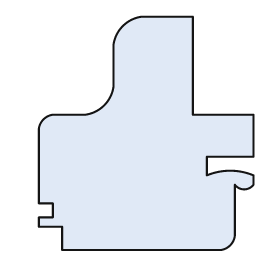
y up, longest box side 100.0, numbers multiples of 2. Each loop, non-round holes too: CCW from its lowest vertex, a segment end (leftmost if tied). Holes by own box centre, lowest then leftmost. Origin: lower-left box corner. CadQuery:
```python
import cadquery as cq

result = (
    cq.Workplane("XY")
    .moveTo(10.0, 0.0)
    .lineTo(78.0, 0.0)
    .threePointArc((82.0, 2.0), (84.0, 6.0))
    .lineTo(84.0, 28.0)
    .threePointArc((88.0, 26.0), (92.0, 28.0))
    .lineTo(92.0, 32.0)
    .threePointArc((82.0, 34.0), (72.0, 32.0))
    .lineTo(72.0, 40.0)
    .lineTo(92.0, 40.0)
    .lineTo(92.0, 58.0)
    .lineTo(66.0, 58.0)
    .lineTo(66.0, 100.0)
    .lineTo(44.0, 100.0)
    .threePointArc((36.0, 96.0), (32.0, 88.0))
    .lineTo(32.0, 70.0)
    .threePointArc((28.0, 62.0), (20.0, 58.0))
    .lineTo(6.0, 58.0)
    .threePointArc((2.0, 56.0), (0.0, 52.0))
    .lineTo(0.0, 20.0)
    .lineTo(6.0, 20.0)
    .lineTo(6.0, 14.0)
    .lineTo(0.0, 14.0)
    .lineTo(0.0, 10.0)
    .lineTo(10.0, 10.0)
    .close()
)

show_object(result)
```